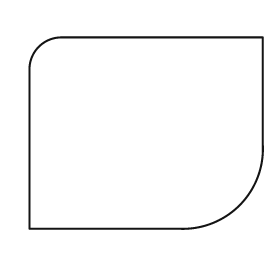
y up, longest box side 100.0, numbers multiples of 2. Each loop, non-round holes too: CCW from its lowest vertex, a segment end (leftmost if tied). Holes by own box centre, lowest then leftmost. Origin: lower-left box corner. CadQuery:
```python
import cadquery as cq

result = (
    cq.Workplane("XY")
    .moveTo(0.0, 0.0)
    .lineTo(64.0, 0.0)
    .threePointArc((90.0, 10.0), (100.0, 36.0))
    .lineTo(100.0, 82.0)
    .lineTo(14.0, 82.0)
    .threePointArc((4.0, 78.0), (0.0, 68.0))
    .close()
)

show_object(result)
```